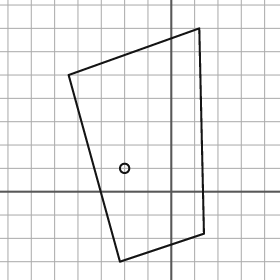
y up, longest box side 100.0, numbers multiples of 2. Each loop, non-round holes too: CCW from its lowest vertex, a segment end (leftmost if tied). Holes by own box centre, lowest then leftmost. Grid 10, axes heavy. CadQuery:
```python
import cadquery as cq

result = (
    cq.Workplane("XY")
    .moveTo(-22.0, -30.0)
    .lineTo(14.0, -18.0)
    .lineTo(12.0, 70.0)
    .lineTo(-44.0, 50.0)
    .close()
    .moveTo(-20.0, 10.0)
    .circle(2.0)
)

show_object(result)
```